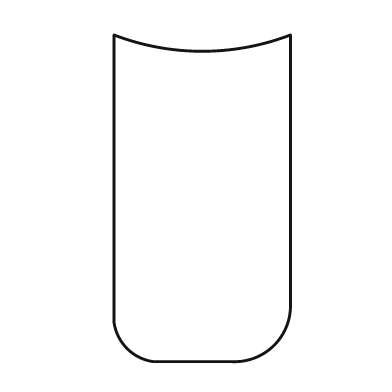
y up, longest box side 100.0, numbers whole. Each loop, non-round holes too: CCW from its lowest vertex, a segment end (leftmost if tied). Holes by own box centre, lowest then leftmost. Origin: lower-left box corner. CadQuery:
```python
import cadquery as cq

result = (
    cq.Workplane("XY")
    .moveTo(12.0, 0.0)
    .lineTo(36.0, 0.0)
    .threePointArc((49.0, 5.0), (54.0, 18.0))
    .lineTo(54.0, 100.0)
    .threePointArc((27.0, 95.0), (0.0, 100.0))
    .lineTo(0.0, 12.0)
    .threePointArc((4.0, 4.0), (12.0, 0.0))
    .close()
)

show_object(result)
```